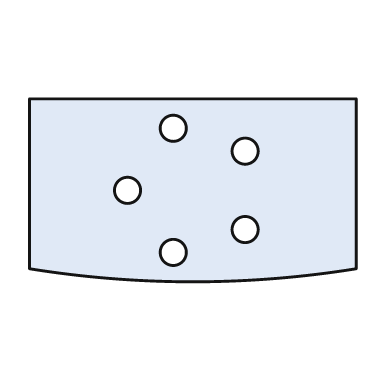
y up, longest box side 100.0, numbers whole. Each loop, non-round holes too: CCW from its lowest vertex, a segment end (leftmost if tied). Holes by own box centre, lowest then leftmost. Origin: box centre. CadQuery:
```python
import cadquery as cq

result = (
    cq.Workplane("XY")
    .moveTo(-50.0, -24.0)
    .threePointArc((0.0, -28.0), (50.0, -24.0))
    .lineTo(50.0, 28.0)
    .lineTo(-50.0, 28.0)
    .close()
    .moveTo(-6.0, -19.0)
    .circle(4.0)
    .moveTo(16.0, -12.0)
    .circle(4.0)
    .moveTo(-20.0, 0.0)
    .circle(4.0)
    .moveTo(16.0, 12.0)
    .circle(4.0)
    .moveTo(-6.0, 19.0)
    .circle(4.0)
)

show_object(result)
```